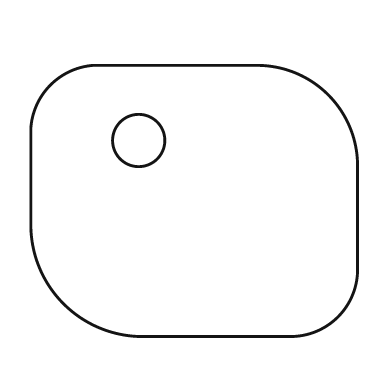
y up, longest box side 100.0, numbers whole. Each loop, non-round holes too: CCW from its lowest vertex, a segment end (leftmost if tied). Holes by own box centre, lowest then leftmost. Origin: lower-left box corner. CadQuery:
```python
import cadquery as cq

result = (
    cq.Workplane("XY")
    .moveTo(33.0, 0.0)
    .lineTo(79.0, 0.0)
    .threePointArc((94.0, 6.0), (100.0, 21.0))
    .lineTo(100.0, 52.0)
    .threePointArc((91.0, 74.0), (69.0, 83.0))
    .lineTo(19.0, 83.0)
    .threePointArc((6.0, 77.0), (0.0, 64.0))
    .lineTo(0.0, 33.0)
    .threePointArc((10.0, 10.0), (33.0, 0.0))
    .close()
    .moveTo(33.0, 60.0)
    .circle(8.0)
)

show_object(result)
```